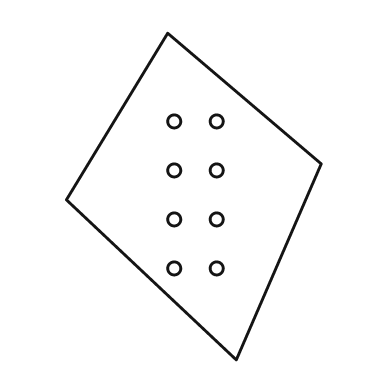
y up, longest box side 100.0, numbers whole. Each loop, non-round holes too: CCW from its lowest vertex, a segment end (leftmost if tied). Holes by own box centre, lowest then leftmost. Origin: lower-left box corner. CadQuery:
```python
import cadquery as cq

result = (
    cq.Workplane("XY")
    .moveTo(52.0, 0.0)
    .lineTo(78.0, 60.0)
    .lineTo(31.0, 100.0)
    .lineTo(0.0, 49.0)
    .close()
    .moveTo(33.0, 28.0)
    .circle(2.0)
    .moveTo(46.0, 28.0)
    .circle(2.0)
    .moveTo(33.0, 43.0)
    .circle(2.0)
    .moveTo(46.0, 43.0)
    .circle(2.0)
    .moveTo(33.0, 58.0)
    .circle(2.0)
    .moveTo(46.0, 58.0)
    .circle(2.0)
    .moveTo(33.0, 73.0)
    .circle(2.0)
    .moveTo(46.0, 73.0)
    .circle(2.0)
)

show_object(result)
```